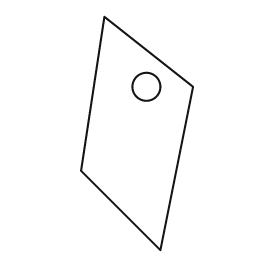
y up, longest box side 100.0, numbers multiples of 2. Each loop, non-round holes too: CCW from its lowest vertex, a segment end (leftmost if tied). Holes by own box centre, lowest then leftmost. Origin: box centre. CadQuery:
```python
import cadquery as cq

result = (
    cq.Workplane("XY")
    .moveTo(10.0, -50.0)
    .lineTo(24.0, 20.0)
    .lineTo(-14.0, 50.0)
    .lineTo(-24.0, -16.0)
    .close()
    .moveTo(4.0, 20.0)
    .circle(6.0)
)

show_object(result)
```